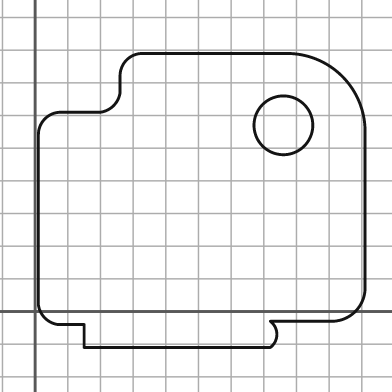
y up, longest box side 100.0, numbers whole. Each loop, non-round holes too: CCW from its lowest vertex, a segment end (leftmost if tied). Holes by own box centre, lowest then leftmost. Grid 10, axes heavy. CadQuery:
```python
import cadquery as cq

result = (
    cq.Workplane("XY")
    .moveTo(15.0, -11.0)
    .lineTo(72.0, -11.0)
    .threePointArc((74.0, -7.0), (72.0, -3.0))
    .lineTo(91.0, -3.0)
    .threePointArc((98.0, 0.0), (101.0, 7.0))
    .lineTo(101.0, 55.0)
    .threePointArc((94.0, 72.0), (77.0, 79.0))
    .lineTo(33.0, 79.0)
    .threePointArc((28.0, 77.0), (26.0, 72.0))
    .lineTo(26.0, 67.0)
    .threePointArc((24.0, 63.0), (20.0, 61.0))
    .lineTo(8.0, 61.0)
    .threePointArc((3.0, 59.0), (1.0, 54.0))
    .lineTo(1.0, 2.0)
    .threePointArc((3.0, -2.0), (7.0, -4.0))
    .lineTo(15.0, -4.0)
    .close()
    .moveTo(76.0, 57.0)
    .circle(9.0)
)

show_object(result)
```